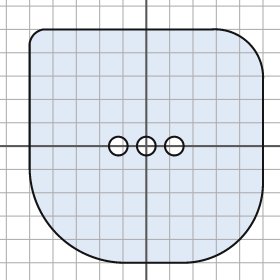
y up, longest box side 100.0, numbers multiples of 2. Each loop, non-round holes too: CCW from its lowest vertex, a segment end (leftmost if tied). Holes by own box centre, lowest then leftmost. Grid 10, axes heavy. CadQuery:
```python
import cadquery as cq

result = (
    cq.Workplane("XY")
    .moveTo(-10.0, -50.0)
    .lineTo(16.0, -50.0)
    .threePointArc((40.0, -40.0), (50.0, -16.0))
    .lineTo(50.0, 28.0)
    .threePointArc((44.0, 44.0), (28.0, 50.0))
    .lineTo(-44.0, 50.0)
    .threePointArc((-48.0, 48.0), (-50.0, 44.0))
    .lineTo(-50.0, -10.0)
    .threePointArc((-38.0, -38.0), (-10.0, -50.0))
    .close()
    .moveTo(-12.0, 0.0)
    .circle(4.0)
    .moveTo(0.0, 0.0)
    .circle(4.0)
    .moveTo(12.0, 0.0)
    .circle(4.0)
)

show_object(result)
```